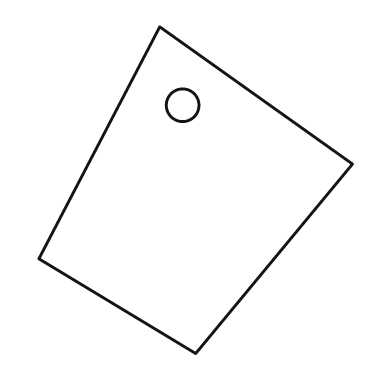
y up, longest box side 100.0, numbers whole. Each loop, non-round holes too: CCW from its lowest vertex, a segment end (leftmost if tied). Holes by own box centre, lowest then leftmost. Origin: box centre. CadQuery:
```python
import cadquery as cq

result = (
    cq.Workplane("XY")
    .moveTo(0.0, -50.0)
    .lineTo(48.0, 8.0)
    .lineTo(-11.0, 50.0)
    .lineTo(-48.0, -21.0)
    .close()
    .moveTo(-4.0, 26.0)
    .circle(5.0)
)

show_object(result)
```